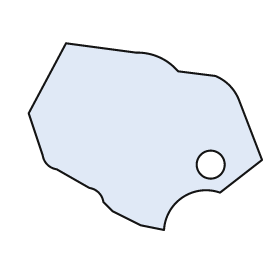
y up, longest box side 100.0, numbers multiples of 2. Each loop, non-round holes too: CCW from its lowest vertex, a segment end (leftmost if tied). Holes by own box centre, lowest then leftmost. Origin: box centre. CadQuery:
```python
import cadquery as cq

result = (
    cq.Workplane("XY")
    .moveTo(8.0, -40.0)
    .threePointArc((16.0, -26.0), (32.0, -24.0))
    .lineTo(50.0, -10.0)
    .lineTo(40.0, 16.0)
    .threePointArc((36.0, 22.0), (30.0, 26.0))
    .lineTo(14.0, 28.0)
    .threePointArc((6.0, 34.0), (-4.0, 36.0))
    .lineTo(-34.0, 40.0)
    .lineTo(-50.0, 10.0)
    .lineTo(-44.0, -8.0)
    .threePointArc((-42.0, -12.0), (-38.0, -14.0))
    .lineTo(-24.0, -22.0)
    .threePointArc((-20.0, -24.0), (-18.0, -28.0))
    .lineTo(-14.0, -32.0)
    .lineTo(-2.0, -38.0)
    .close()
    .moveTo(28.0, -12.0)
    .circle(6.0)
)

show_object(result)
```